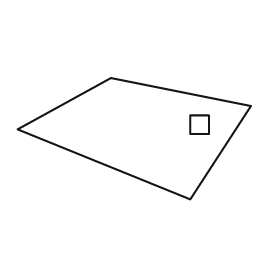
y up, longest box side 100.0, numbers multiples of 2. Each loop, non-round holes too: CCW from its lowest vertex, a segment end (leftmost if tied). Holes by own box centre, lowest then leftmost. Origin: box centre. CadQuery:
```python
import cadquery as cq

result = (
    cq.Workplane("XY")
    .moveTo(24.0, -26.0)
    .lineTo(50.0, 14.0)
    .lineTo(-10.0, 26.0)
    .lineTo(-50.0, 4.0)
    .close()
    .moveTo(24.0, 2.0)
    .lineTo(32.0, 2.0)
    .lineTo(32.0, 10.0)
    .lineTo(24.0, 10.0)
    .close()
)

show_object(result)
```